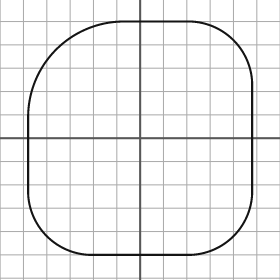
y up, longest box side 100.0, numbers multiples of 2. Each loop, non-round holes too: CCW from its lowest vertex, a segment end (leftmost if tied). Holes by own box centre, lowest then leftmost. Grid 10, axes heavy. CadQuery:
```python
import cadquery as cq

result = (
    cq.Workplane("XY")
    .moveTo(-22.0, -50.0)
    .lineTo(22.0, -50.0)
    .threePointArc((40.0, -42.0), (48.0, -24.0))
    .lineTo(48.0, 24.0)
    .threePointArc((40.0, 42.0), (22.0, 50.0))
    .lineTo(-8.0, 50.0)
    .threePointArc((-36.0, 38.0), (-48.0, 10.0))
    .lineTo(-48.0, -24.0)
    .threePointArc((-40.0, -42.0), (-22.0, -50.0))
    .close()
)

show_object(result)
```